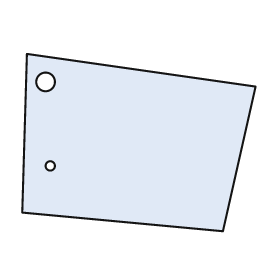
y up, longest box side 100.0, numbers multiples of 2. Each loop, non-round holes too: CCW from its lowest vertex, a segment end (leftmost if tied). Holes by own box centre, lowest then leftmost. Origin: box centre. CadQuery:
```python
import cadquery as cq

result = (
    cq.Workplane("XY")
    .moveTo(36.0, -38.0)
    .lineTo(50.0, 24.0)
    .lineTo(-48.0, 38.0)
    .lineTo(-50.0, -30.0)
    .close()
    .moveTo(-38.0, -10.0)
    .circle(2.0)
    .moveTo(-40.0, 26.0)
    .circle(4.0)
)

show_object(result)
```